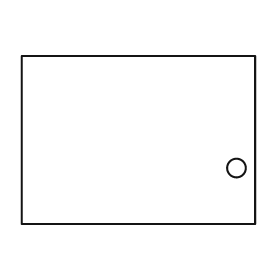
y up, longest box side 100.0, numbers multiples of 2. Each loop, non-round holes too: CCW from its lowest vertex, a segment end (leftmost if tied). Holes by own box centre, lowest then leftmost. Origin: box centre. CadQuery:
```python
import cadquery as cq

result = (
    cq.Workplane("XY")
    .moveTo(-50.0, -36.0)
    .lineTo(50.0, -36.0)
    .lineTo(50.0, 36.0)
    .lineTo(-50.0, 36.0)
    .close()
    .moveTo(42.0, -12.0)
    .circle(4.0)
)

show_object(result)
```